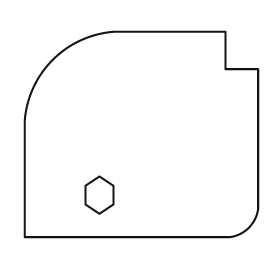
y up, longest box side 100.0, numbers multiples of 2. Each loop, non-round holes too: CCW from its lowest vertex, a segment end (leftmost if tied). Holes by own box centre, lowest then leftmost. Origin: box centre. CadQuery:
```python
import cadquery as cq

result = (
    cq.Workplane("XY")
    .moveTo(-50.0, -44.0)
    .lineTo(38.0, -44.0)
    .threePointArc((46.0, -40.0), (50.0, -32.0))
    .lineTo(50.0, 28.0)
    .lineTo(36.0, 28.0)
    .lineTo(36.0, 44.0)
    .lineTo(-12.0, 44.0)
    .threePointArc((-38.0, 32.0), (-50.0, 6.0))
    .close()
    .moveTo(-18.0, -34.0)
    .lineTo(-12.0, -30.0)
    .lineTo(-12.0, -22.0)
    .lineTo(-18.0, -18.0)
    .lineTo(-24.0, -22.0)
    .lineTo(-24.0, -30.0)
    .close()
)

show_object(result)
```